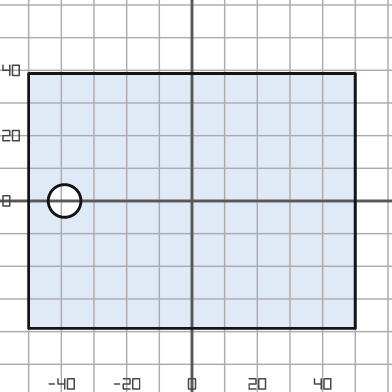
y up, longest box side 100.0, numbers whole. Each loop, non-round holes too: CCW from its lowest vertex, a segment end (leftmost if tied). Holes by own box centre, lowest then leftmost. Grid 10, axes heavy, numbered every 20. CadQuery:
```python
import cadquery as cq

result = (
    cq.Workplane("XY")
    .moveTo(-50.0, -39.0)
    .lineTo(50.0, -39.0)
    .lineTo(50.0, 39.0)
    .lineTo(-50.0, 39.0)
    .close()
    .moveTo(-39.0, 0.0)
    .circle(5.0)
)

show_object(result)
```